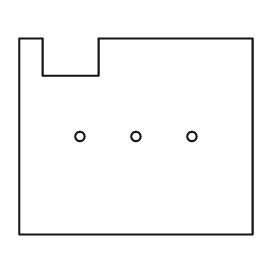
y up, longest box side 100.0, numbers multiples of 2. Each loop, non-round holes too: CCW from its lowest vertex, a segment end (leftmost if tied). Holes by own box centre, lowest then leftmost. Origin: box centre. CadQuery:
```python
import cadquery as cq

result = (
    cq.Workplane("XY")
    .moveTo(-50.0, -42.0)
    .lineTo(50.0, -42.0)
    .lineTo(50.0, 42.0)
    .lineTo(-16.0, 42.0)
    .lineTo(-16.0, 26.0)
    .lineTo(-40.0, 26.0)
    .lineTo(-40.0, 42.0)
    .lineTo(-50.0, 42.0)
    .close()
    .moveTo(-24.0, 0.0)
    .circle(2.0)
    .moveTo(0.0, 0.0)
    .circle(2.0)
    .moveTo(24.0, 0.0)
    .circle(2.0)
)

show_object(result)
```